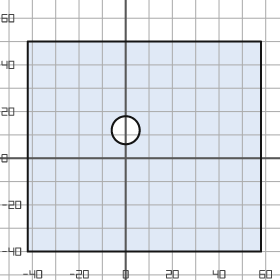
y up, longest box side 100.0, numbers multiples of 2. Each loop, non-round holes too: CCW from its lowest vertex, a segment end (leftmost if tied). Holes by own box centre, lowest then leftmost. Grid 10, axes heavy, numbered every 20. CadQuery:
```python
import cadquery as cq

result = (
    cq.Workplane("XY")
    .moveTo(-42.0, -40.0)
    .lineTo(58.0, -40.0)
    .lineTo(58.0, 50.0)
    .lineTo(-42.0, 50.0)
    .close()
    .moveTo(0.0, 12.0)
    .circle(6.0)
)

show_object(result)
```